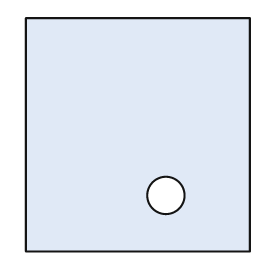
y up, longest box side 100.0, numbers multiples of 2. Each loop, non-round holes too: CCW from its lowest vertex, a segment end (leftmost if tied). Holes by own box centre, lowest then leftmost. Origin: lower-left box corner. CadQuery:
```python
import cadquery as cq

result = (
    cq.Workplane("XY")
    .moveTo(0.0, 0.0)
    .lineTo(96.0, 0.0)
    .lineTo(96.0, 100.0)
    .lineTo(0.0, 100.0)
    .close()
    .moveTo(60.0, 24.0)
    .circle(8.0)
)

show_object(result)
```